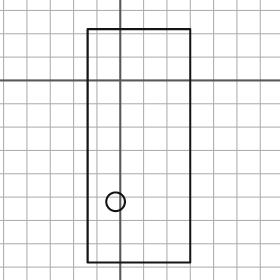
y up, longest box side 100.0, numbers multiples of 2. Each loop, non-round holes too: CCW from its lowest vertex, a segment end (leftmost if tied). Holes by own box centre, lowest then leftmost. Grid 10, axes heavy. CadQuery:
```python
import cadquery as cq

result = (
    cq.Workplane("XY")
    .moveTo(-14.0, -78.0)
    .lineTo(30.0, -78.0)
    .lineTo(30.0, 22.0)
    .lineTo(-14.0, 22.0)
    .close()
    .moveTo(-2.0, -52.0)
    .circle(4.0)
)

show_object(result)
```